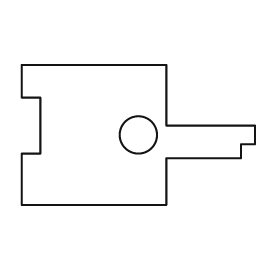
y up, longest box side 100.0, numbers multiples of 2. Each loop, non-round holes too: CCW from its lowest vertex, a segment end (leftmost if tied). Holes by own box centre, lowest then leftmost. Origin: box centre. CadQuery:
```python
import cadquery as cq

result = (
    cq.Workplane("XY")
    .moveTo(-50.0, -30.0)
    .lineTo(12.0, -30.0)
    .lineTo(12.0, -10.0)
    .lineTo(44.0, -10.0)
    .lineTo(44.0, -4.0)
    .lineTo(50.0, -4.0)
    .lineTo(50.0, 4.0)
    .lineTo(12.0, 4.0)
    .lineTo(12.0, 30.0)
    .lineTo(-50.0, 30.0)
    .lineTo(-50.0, 16.0)
    .lineTo(-42.0, 16.0)
    .lineTo(-42.0, -8.0)
    .lineTo(-50.0, -8.0)
    .close()
    .moveTo(0.0, 0.0)
    .circle(8.0)
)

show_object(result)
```